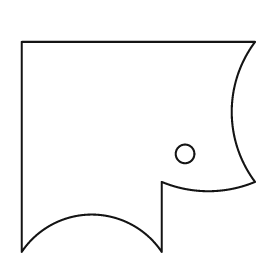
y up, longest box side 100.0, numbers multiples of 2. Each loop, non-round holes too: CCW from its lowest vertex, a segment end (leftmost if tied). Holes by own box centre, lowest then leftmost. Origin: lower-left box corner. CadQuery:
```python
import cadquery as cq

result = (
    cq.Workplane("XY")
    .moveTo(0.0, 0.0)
    .threePointArc((30.0, 16.0), (60.0, 0.0))
    .lineTo(60.0, 30.0)
    .threePointArc((80.0, 26.0), (100.0, 30.0))
    .threePointArc((90.0, 60.0), (100.0, 90.0))
    .lineTo(0.0, 90.0)
    .close()
    .moveTo(70.0, 42.0)
    .circle(4.0)
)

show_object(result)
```